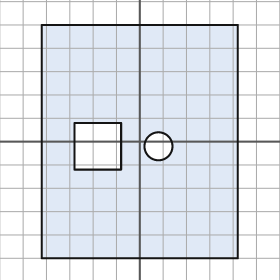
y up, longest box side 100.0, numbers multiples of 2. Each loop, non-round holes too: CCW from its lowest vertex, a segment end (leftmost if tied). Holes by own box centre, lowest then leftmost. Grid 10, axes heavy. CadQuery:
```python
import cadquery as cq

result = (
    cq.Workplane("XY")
    .moveTo(-42.0, -50.0)
    .lineTo(42.0, -50.0)
    .lineTo(42.0, 50.0)
    .lineTo(-42.0, 50.0)
    .close()
    .moveTo(-28.0, -12.0)
    .lineTo(-8.0, -12.0)
    .lineTo(-8.0, 8.0)
    .lineTo(-28.0, 8.0)
    .close()
    .moveTo(8.0, -2.0)
    .circle(6.0)
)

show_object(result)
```